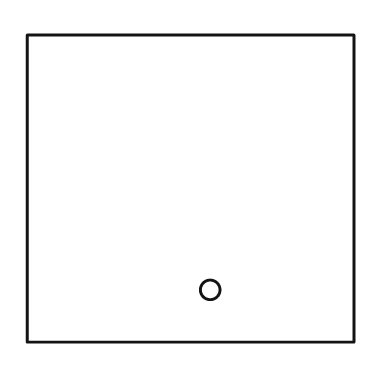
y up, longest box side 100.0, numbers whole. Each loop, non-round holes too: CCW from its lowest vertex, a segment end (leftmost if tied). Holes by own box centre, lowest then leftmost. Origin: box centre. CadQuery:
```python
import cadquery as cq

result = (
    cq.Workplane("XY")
    .moveTo(-50.0, -47.0)
    .lineTo(50.0, -47.0)
    .lineTo(50.0, 47.0)
    .lineTo(-50.0, 47.0)
    .close()
    .moveTo(6.0, -31.0)
    .circle(3.0)
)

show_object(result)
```